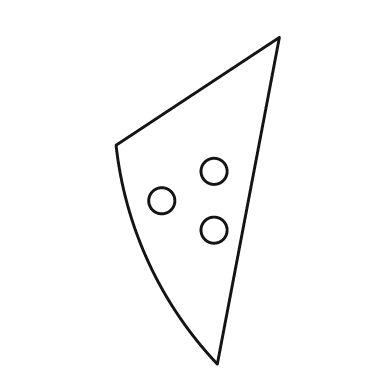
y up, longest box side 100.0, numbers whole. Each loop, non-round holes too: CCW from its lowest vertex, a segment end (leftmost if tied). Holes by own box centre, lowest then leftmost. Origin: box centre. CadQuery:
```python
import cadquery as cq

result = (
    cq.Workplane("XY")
    .moveTo(6.0, -50.0)
    .lineTo(25.0, 50.0)
    .lineTo(-25.0, 17.0)
    .threePointArc((-15.0, -19.0), (6.0, -50.0))
    .close()
    .moveTo(5.0, -9.0)
    .circle(4.0)
    .moveTo(-11.0, 0.0)
    .circle(4.0)
    .moveTo(5.0, 9.0)
    .circle(4.0)
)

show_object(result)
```